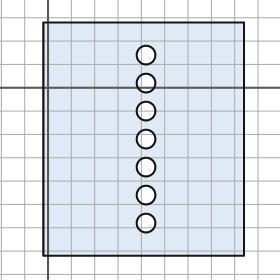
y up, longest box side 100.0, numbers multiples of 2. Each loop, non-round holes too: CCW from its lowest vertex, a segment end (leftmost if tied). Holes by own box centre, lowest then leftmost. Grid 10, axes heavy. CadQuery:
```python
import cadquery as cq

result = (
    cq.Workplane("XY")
    .moveTo(-2.0, -72.0)
    .lineTo(84.0, -72.0)
    .lineTo(84.0, 28.0)
    .lineTo(-2.0, 28.0)
    .close()
    .moveTo(42.0, -58.0)
    .circle(4.0)
    .moveTo(42.0, -46.0)
    .circle(4.0)
    .moveTo(42.0, -34.0)
    .circle(4.0)
    .moveTo(42.0, -22.0)
    .circle(4.0)
    .moveTo(42.0, -10.0)
    .circle(4.0)
    .moveTo(42.0, 2.0)
    .circle(4.0)
    .moveTo(42.0, 14.0)
    .circle(4.0)
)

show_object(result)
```